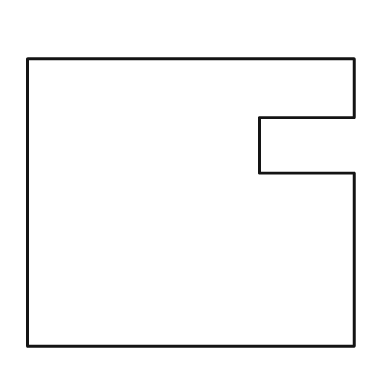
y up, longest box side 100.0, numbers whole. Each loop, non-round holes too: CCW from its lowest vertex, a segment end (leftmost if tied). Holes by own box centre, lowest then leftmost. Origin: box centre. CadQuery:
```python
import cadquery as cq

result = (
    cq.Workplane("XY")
    .moveTo(-50.0, -44.0)
    .lineTo(50.0, -44.0)
    .lineTo(50.0, 9.0)
    .lineTo(21.0, 9.0)
    .lineTo(21.0, 26.0)
    .lineTo(50.0, 26.0)
    .lineTo(50.0, 44.0)
    .lineTo(-50.0, 44.0)
    .close()
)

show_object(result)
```